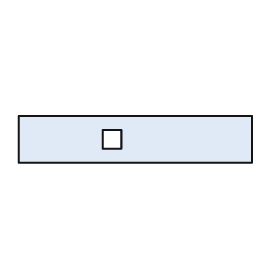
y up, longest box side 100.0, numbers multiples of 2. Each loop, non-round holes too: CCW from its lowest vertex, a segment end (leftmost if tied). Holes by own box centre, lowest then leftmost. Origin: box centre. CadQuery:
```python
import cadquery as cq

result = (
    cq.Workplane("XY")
    .moveTo(-50.0, -10.0)
    .lineTo(50.0, -10.0)
    .lineTo(50.0, 10.0)
    .lineTo(-50.0, 10.0)
    .close()
    .moveTo(-14.0, -4.0)
    .lineTo(-6.0, -4.0)
    .lineTo(-6.0, 4.0)
    .lineTo(-14.0, 4.0)
    .close()
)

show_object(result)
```